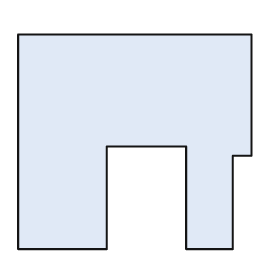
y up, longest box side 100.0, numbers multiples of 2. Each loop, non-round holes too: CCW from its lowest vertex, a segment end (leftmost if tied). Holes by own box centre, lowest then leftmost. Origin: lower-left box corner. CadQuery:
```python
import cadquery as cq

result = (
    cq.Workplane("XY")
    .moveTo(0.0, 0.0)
    .lineTo(38.0, 0.0)
    .lineTo(38.0, 44.0)
    .lineTo(72.0, 44.0)
    .lineTo(72.0, 0.0)
    .lineTo(92.0, 0.0)
    .lineTo(92.0, 40.0)
    .lineTo(100.0, 40.0)
    .lineTo(100.0, 92.0)
    .lineTo(0.0, 92.0)
    .close()
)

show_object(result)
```